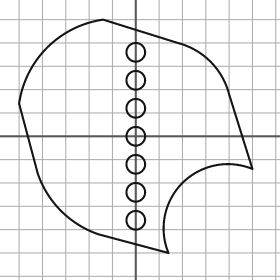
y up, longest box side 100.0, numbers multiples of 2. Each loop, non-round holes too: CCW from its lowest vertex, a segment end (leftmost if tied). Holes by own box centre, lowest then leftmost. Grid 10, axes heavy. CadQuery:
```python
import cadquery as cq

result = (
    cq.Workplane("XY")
    .moveTo(14.0, -50.0)
    .threePointArc((20.0, -20.0), (50.0, -14.0))
    .lineTo(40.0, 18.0)
    .threePointArc((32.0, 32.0), (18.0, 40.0))
    .lineTo(-14.0, 50.0)
    .threePointArc((-38.0, 38.0), (-50.0, 14.0))
    .lineTo(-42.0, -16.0)
    .threePointArc((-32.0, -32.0), (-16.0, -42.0))
    .close()
    .moveTo(0.0, -36.0)
    .circle(4.0)
    .moveTo(0.0, -24.0)
    .circle(4.0)
    .moveTo(0.0, -12.0)
    .circle(4.0)
    .moveTo(0.0, 0.0)
    .circle(4.0)
    .moveTo(0.0, 12.0)
    .circle(4.0)
    .moveTo(0.0, 24.0)
    .circle(4.0)
    .moveTo(0.0, 36.0)
    .circle(4.0)
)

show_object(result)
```